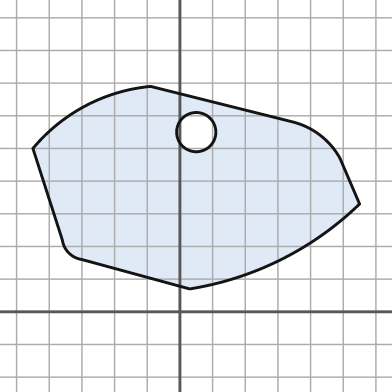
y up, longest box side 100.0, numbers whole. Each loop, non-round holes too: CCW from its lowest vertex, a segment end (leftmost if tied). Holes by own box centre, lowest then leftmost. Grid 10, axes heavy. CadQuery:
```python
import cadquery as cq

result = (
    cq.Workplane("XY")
    .moveTo(3.0, 7.0)
    .threePointArc((31.0, 16.0), (55.0, 33.0))
    .lineTo(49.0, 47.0)
    .threePointArc((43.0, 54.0), (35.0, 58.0))
    .lineTo(-9.0, 69.0)
    .threePointArc((-29.0, 63.0), (-45.0, 50.0))
    .lineTo(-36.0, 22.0)
    .threePointArc((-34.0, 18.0), (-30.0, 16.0))
    .close()
    .moveTo(5.0, 55.0)
    .circle(6.0)
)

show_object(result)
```